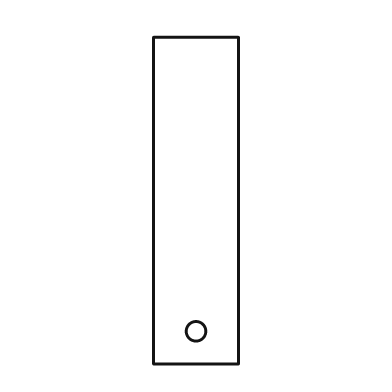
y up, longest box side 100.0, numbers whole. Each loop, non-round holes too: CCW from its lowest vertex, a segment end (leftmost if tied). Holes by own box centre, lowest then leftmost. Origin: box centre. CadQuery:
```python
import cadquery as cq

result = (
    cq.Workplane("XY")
    .moveTo(-13.0, -50.0)
    .lineTo(13.0, -50.0)
    .lineTo(13.0, 50.0)
    .lineTo(-13.0, 50.0)
    .close()
    .moveTo(0.0, -40.0)
    .circle(3.0)
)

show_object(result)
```